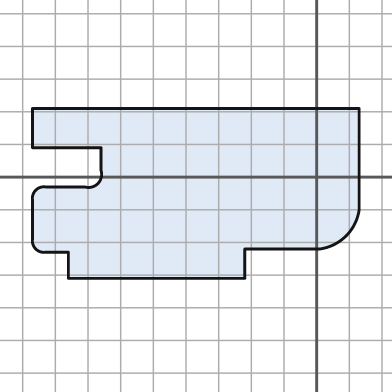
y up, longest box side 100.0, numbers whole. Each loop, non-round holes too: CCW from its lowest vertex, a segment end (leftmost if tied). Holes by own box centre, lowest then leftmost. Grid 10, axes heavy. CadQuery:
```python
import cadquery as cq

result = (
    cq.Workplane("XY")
    .moveTo(-76.0, -31.0)
    .lineTo(-22.0, -31.0)
    .lineTo(-22.0, -22.0)
    .lineTo(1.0, -22.0)
    .threePointArc((9.0, -18.0), (13.0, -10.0))
    .lineTo(13.0, 21.0)
    .lineTo(-87.0, 21.0)
    .lineTo(-87.0, 9.0)
    .lineTo(-66.0, 9.0)
    .lineTo(-66.0, 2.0)
    .threePointArc((-67.0, -2.0), (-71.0, -3.0))
    .lineTo(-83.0, -3.0)
    .threePointArc((-86.0, -4.0), (-87.0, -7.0))
    .lineTo(-87.0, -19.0)
    .threePointArc((-86.0, -22.0), (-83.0, -23.0))
    .lineTo(-76.0, -23.0)
    .close()
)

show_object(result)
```